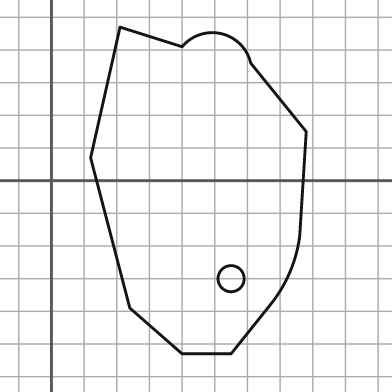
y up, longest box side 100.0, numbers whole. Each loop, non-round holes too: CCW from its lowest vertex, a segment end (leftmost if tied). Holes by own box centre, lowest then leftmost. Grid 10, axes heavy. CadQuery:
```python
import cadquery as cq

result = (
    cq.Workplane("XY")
    .moveTo(40.0, -53.0)
    .lineTo(55.0, -53.0)
    .lineTo(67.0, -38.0)
    .threePointArc((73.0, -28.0), (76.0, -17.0))
    .lineTo(78.0, 15.0)
    .lineTo(61.0, 36.0)
    .threePointArc((52.0, 45.0), (40.0, 41.0))
    .lineTo(21.0, 47.0)
    .lineTo(12.0, 7.0)
    .lineTo(24.0, -39.0)
    .close()
    .moveTo(55.0, -30.0)
    .circle(4.0)
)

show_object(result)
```